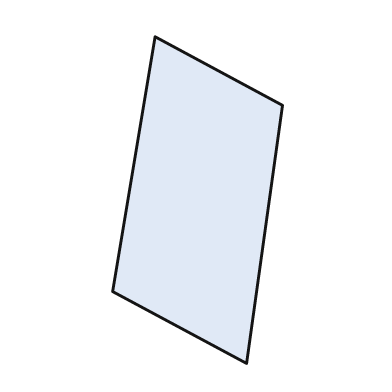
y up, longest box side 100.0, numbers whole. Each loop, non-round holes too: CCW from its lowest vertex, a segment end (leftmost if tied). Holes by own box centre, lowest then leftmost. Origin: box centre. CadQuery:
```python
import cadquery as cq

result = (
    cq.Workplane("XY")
    .moveTo(15.0, -50.0)
    .lineTo(26.0, 29.0)
    .lineTo(-13.0, 50.0)
    .lineTo(-26.0, -28.0)
    .close()
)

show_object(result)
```